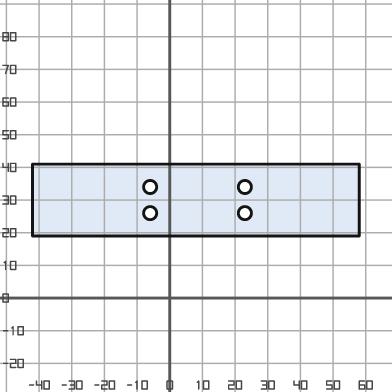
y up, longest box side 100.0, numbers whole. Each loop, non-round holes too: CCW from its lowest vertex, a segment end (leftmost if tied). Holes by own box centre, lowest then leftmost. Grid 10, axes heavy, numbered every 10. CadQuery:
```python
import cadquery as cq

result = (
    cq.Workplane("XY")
    .moveTo(-42.0, 19.0)
    .lineTo(58.0, 19.0)
    .lineTo(58.0, 41.0)
    .lineTo(-42.0, 41.0)
    .close()
    .moveTo(-6.0, 26.0)
    .circle(2.0)
    .moveTo(23.0, 26.0)
    .circle(2.0)
    .moveTo(-6.0, 34.0)
    .circle(2.0)
    .moveTo(23.0, 34.0)
    .circle(2.0)
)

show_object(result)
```